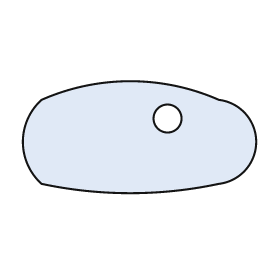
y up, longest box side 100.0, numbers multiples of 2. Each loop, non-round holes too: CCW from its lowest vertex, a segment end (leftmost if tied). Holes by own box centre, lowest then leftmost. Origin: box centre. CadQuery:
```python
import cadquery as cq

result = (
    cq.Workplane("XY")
    .moveTo(-42.0, -20.0)
    .threePointArc((-4.0, -24.0), (34.0, -20.0))
    .threePointArc((50.0, -2.0), (34.0, 16.0))
    .threePointArc((-4.0, 24.0), (-42.0, 16.0))
    .threePointArc((-50.0, -2.0), (-42.0, -20.0))
    .close()
    .moveTo(12.0, 8.0)
    .circle(6.0)
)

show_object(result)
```